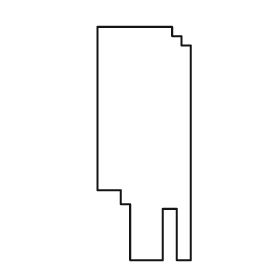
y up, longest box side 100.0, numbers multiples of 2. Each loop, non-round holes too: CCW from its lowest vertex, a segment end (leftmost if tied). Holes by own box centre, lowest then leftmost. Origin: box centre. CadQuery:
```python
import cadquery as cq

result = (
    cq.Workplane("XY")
    .moveTo(-6.0, -50.0)
    .lineTo(8.0, -50.0)
    .lineTo(8.0, -28.0)
    .lineTo(14.0, -28.0)
    .lineTo(14.0, -50.0)
    .lineTo(20.0, -50.0)
    .lineTo(20.0, 42.0)
    .lineTo(16.0, 42.0)
    .lineTo(16.0, 46.0)
    .lineTo(12.0, 46.0)
    .lineTo(12.0, 50.0)
    .lineTo(-20.0, 50.0)
    .lineTo(-20.0, -20.0)
    .lineTo(-10.0, -20.0)
    .lineTo(-10.0, -26.0)
    .lineTo(-6.0, -26.0)
    .close()
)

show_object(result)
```